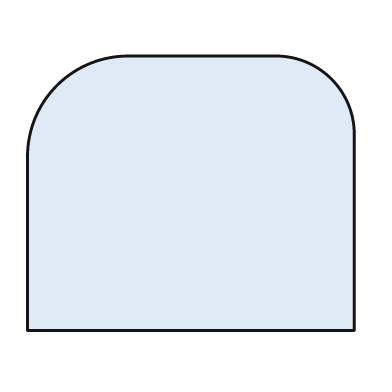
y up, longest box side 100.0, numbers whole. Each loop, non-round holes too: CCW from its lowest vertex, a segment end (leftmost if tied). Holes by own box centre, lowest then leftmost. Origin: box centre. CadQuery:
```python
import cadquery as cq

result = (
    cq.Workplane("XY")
    .moveTo(-50.0, -42.0)
    .lineTo(50.0, -42.0)
    .lineTo(50.0, 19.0)
    .threePointArc((43.0, 35.0), (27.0, 42.0))
    .lineTo(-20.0, 42.0)
    .threePointArc((-41.0, 33.0), (-50.0, 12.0))
    .close()
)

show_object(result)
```